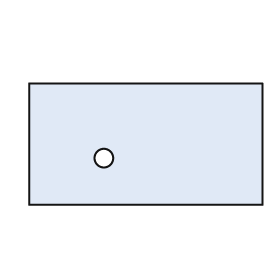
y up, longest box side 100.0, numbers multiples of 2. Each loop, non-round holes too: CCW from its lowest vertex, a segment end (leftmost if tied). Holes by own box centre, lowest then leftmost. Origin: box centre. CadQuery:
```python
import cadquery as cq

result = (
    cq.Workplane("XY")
    .moveTo(-50.0, -26.0)
    .lineTo(50.0, -26.0)
    .lineTo(50.0, 26.0)
    .lineTo(-50.0, 26.0)
    .close()
    .moveTo(-18.0, -6.0)
    .circle(4.0)
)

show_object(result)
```